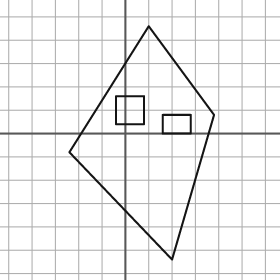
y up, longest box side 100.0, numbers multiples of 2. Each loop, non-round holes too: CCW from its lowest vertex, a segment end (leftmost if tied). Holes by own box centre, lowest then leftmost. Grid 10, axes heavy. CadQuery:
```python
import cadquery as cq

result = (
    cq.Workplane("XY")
    .moveTo(20.0, -54.0)
    .lineTo(38.0, 8.0)
    .lineTo(10.0, 46.0)
    .lineTo(-24.0, -8.0)
    .close()
    .moveTo(16.0, 0.0)
    .lineTo(28.0, 0.0)
    .lineTo(28.0, 8.0)
    .lineTo(16.0, 8.0)
    .close()
    .moveTo(-4.0, 4.0)
    .lineTo(8.0, 4.0)
    .lineTo(8.0, 16.0)
    .lineTo(-4.0, 16.0)
    .close()
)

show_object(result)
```